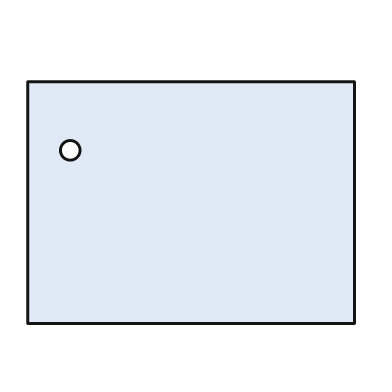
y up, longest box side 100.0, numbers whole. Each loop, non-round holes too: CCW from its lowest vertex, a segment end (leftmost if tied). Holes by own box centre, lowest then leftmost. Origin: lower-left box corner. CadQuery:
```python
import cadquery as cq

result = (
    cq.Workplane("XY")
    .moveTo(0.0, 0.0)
    .lineTo(100.0, 0.0)
    .lineTo(100.0, 74.0)
    .lineTo(0.0, 74.0)
    .close()
    .moveTo(13.0, 53.0)
    .circle(3.0)
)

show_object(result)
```